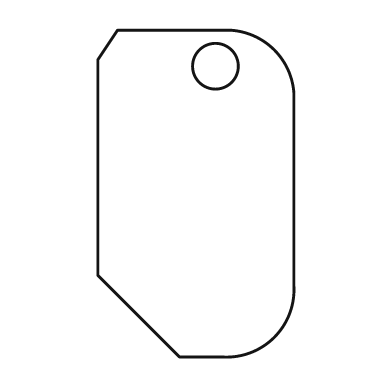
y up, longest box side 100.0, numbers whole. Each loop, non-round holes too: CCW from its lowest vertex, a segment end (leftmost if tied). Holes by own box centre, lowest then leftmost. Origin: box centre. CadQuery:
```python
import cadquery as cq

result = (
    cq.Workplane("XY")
    .moveTo(-5.0, -50.0)
    .lineTo(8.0, -50.0)
    .threePointArc((24.0, -44.0), (30.0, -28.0))
    .lineTo(30.0, 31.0)
    .threePointArc((24.0, 44.0), (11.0, 50.0))
    .lineTo(-24.0, 50.0)
    .lineTo(-30.0, 41.0)
    .lineTo(-30.0, -25.0)
    .close()
    .moveTo(6.0, 39.0)
    .circle(7.0)
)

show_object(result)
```